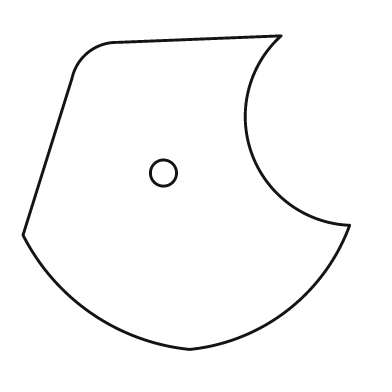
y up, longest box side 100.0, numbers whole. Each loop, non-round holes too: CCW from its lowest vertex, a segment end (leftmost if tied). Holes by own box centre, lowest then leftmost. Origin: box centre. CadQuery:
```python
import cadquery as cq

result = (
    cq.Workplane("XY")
    .moveTo(1.0, -48.0)
    .threePointArc((31.0, -36.0), (50.0, -10.0))
    .threePointArc((20.0, 12.0), (29.0, 48.0))
    .lineTo(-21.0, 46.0)
    .threePointArc((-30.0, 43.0), (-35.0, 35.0))
    .lineTo(-50.0, -13.0)
    .threePointArc((-29.0, -37.0), (1.0, -48.0))
    .close()
    .moveTo(-7.0, 6.0)
    .circle(4.0)
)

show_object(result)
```